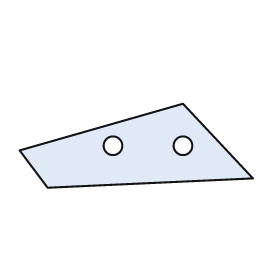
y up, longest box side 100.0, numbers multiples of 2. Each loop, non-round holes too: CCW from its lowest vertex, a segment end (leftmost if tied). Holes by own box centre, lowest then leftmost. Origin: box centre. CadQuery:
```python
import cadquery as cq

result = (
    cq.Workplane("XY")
    .moveTo(-38.0, -18.0)
    .lineTo(50.0, -14.0)
    .lineTo(20.0, 18.0)
    .lineTo(-50.0, -2.0)
    .close()
    .moveTo(-10.0, 0.0)
    .circle(4.0)
    .moveTo(20.0, 0.0)
    .circle(4.0)
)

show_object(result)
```